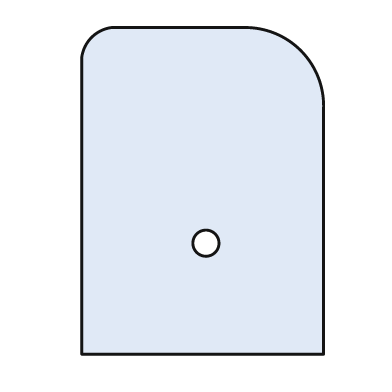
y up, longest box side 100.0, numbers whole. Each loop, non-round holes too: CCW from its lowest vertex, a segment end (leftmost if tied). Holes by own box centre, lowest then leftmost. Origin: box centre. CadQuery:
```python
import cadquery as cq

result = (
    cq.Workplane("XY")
    .moveTo(-37.0, -50.0)
    .lineTo(37.0, -50.0)
    .lineTo(37.0, 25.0)
    .threePointArc((30.0, 43.0), (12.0, 50.0))
    .lineTo(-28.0, 50.0)
    .threePointArc((-34.0, 47.0), (-37.0, 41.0))
    .close()
    .moveTo(1.0, -16.0)
    .circle(4.0)
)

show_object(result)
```